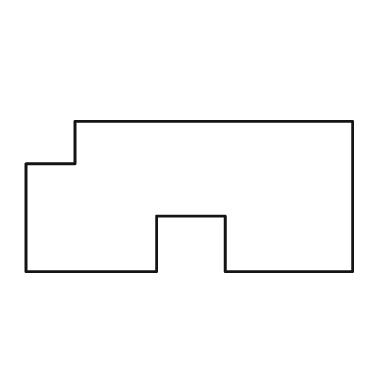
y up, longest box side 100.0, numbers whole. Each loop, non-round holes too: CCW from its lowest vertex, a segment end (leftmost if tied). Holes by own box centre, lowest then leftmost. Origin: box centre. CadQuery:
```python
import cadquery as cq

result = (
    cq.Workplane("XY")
    .moveTo(-50.0, -23.0)
    .lineTo(-10.0, -23.0)
    .lineTo(-10.0, -6.0)
    .lineTo(11.0, -6.0)
    .lineTo(11.0, -23.0)
    .lineTo(50.0, -23.0)
    .lineTo(50.0, 23.0)
    .lineTo(-35.0, 23.0)
    .lineTo(-35.0, 10.0)
    .lineTo(-50.0, 10.0)
    .close()
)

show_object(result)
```